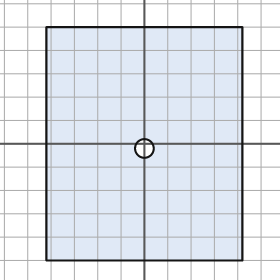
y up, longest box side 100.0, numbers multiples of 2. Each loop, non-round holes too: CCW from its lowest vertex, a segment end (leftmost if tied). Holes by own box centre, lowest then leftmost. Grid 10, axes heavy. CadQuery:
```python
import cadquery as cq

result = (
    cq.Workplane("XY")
    .moveTo(-42.0, -50.0)
    .lineTo(42.0, -50.0)
    .lineTo(42.0, 50.0)
    .lineTo(-42.0, 50.0)
    .close()
    .moveTo(0.0, -2.0)
    .circle(4.0)
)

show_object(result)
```